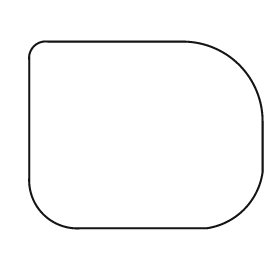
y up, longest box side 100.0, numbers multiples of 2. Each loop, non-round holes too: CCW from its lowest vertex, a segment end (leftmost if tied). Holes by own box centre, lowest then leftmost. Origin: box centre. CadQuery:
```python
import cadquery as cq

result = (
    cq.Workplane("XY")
    .moveTo(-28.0, -40.0)
    .lineTo(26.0, -40.0)
    .threePointArc((42.0, -32.0), (50.0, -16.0))
    .lineTo(50.0, 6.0)
    .threePointArc((40.0, 30.0), (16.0, 40.0))
    .lineTo(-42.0, 40.0)
    .threePointArc((-48.0, 38.0), (-50.0, 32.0))
    .lineTo(-50.0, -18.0)
    .threePointArc((-44.0, -34.0), (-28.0, -40.0))
    .close()
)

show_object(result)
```